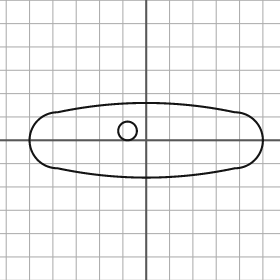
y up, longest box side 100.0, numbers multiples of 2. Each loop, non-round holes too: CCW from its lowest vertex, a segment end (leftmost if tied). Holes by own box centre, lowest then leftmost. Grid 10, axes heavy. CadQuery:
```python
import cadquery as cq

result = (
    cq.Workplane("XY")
    .moveTo(-38.0, -12.0)
    .threePointArc((0.0, -16.0), (38.0, -12.0))
    .threePointArc((50.0, 0.0), (38.0, 12.0))
    .threePointArc((0.0, 16.0), (-38.0, 12.0))
    .threePointArc((-50.0, 0.0), (-38.0, -12.0))
    .close()
    .moveTo(-8.0, 4.0)
    .circle(4.0)
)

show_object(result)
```